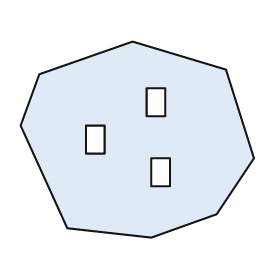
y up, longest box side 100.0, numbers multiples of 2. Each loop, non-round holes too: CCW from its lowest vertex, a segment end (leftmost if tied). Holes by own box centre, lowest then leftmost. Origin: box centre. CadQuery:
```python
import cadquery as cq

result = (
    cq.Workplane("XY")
    .moveTo(6.0, -42.0)
    .lineTo(34.0, -32.0)
    .lineTo(50.0, -8.0)
    .lineTo(38.0, 30.0)
    .lineTo(-2.0, 42.0)
    .lineTo(-42.0, 28.0)
    .lineTo(-50.0, 6.0)
    .lineTo(-30.0, -38.0)
    .close()
    .moveTo(6.0, -20.0)
    .lineTo(14.0, -20.0)
    .lineTo(14.0, -8.0)
    .lineTo(6.0, -8.0)
    .close()
    .moveTo(-22.0, -6.0)
    .lineTo(-14.0, -6.0)
    .lineTo(-14.0, 6.0)
    .lineTo(-22.0, 6.0)
    .close()
    .moveTo(4.0, 10.0)
    .lineTo(12.0, 10.0)
    .lineTo(12.0, 22.0)
    .lineTo(4.0, 22.0)
    .close()
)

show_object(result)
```